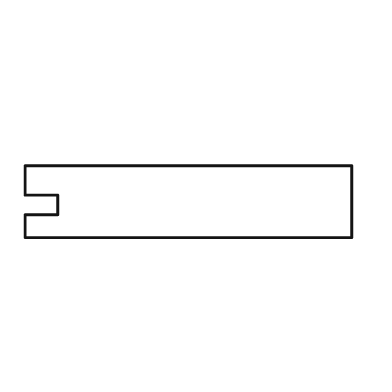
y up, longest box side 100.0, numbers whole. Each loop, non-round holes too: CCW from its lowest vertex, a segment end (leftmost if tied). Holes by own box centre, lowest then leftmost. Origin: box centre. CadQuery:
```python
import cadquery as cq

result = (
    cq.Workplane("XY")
    .moveTo(-50.0, -11.0)
    .lineTo(50.0, -11.0)
    .lineTo(50.0, 11.0)
    .lineTo(-50.0, 11.0)
    .lineTo(-50.0, 2.0)
    .lineTo(-40.0, 2.0)
    .lineTo(-40.0, -4.0)
    .lineTo(-50.0, -4.0)
    .close()
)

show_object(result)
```